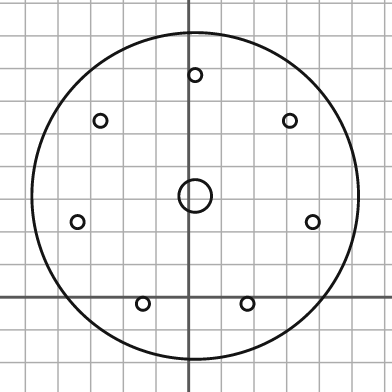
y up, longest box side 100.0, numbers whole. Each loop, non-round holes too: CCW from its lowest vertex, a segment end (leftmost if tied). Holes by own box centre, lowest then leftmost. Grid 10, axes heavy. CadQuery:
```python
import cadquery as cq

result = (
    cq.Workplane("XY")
    .moveTo(2.0, 31.0)
    .circle(50.0)
    .moveTo(-14.0, -2.0)
    .circle(2.0)
    .moveTo(18.0, -2.0)
    .circle(2.0)
    .moveTo(-34.0, 23.0)
    .circle(2.0)
    .moveTo(38.0, 23.0)
    .circle(2.0)
    .moveTo(2.0, 31.0)
    .circle(5.0)
    .moveTo(-27.0, 54.0)
    .circle(2.0)
    .moveTo(31.0, 54.0)
    .circle(2.0)
    .moveTo(2.0, 68.0)
    .circle(2.0)
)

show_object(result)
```